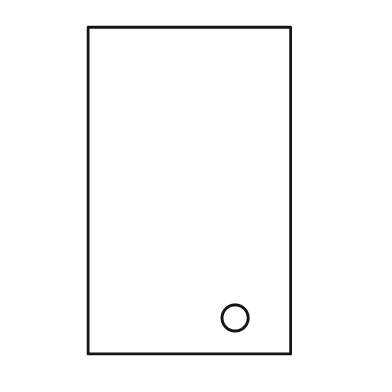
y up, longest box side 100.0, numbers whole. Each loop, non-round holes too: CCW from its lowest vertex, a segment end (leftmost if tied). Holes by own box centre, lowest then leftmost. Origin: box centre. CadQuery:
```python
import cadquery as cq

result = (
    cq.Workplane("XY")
    .moveTo(-31.0, -50.0)
    .lineTo(31.0, -50.0)
    .lineTo(31.0, 50.0)
    .lineTo(-31.0, 50.0)
    .close()
    .moveTo(14.0, -39.0)
    .circle(4.0)
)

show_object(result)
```